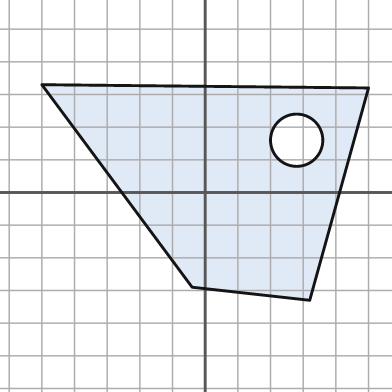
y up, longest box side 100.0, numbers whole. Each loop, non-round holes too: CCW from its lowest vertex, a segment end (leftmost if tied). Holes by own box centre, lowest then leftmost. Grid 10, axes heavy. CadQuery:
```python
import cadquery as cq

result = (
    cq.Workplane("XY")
    .moveTo(32.0, -33.0)
    .lineTo(50.0, 32.0)
    .lineTo(-50.0, 33.0)
    .lineTo(-4.0, -29.0)
    .close()
    .moveTo(28.0, 16.0)
    .circle(8.0)
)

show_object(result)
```